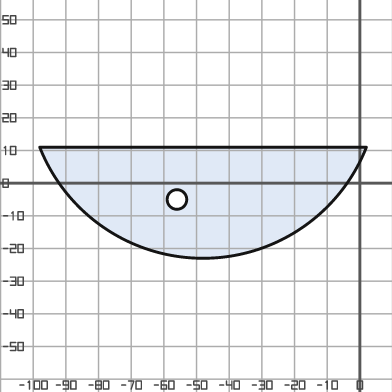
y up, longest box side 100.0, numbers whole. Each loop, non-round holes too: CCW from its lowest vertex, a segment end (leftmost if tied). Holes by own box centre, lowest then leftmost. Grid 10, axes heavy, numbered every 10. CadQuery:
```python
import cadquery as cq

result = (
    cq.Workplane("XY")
    .moveTo(-98.0, 11.0)
    .threePointArc((-48.0, -23.0), (2.0, 11.0))
    .close()
    .moveTo(-56.0, -5.0)
    .circle(3.0)
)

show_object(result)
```